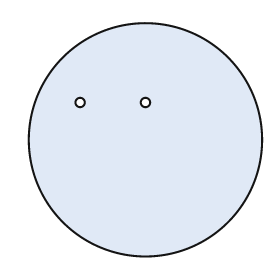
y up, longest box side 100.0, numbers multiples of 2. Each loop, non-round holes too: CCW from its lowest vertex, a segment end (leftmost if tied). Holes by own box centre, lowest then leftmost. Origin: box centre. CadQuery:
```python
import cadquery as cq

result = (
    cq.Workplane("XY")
    .moveTo(0.0, 0.0)
    .circle(50.0)
    .moveTo(-28.0, 16.0)
    .circle(2.0)
    .moveTo(0.0, 16.0)
    .circle(2.0)
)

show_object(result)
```